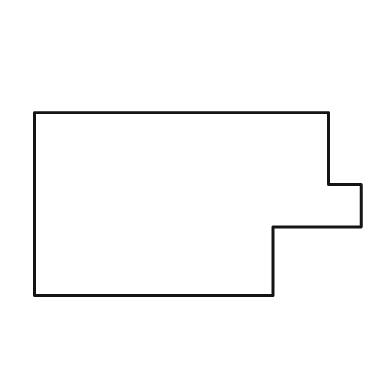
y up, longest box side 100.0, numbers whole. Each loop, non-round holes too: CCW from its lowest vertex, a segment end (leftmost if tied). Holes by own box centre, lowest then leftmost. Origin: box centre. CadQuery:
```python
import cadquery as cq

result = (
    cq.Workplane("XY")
    .moveTo(-50.0, -28.0)
    .lineTo(23.0, -28.0)
    .lineTo(23.0, -7.0)
    .lineTo(50.0, -7.0)
    .lineTo(50.0, 6.0)
    .lineTo(40.0, 6.0)
    .lineTo(40.0, 28.0)
    .lineTo(-50.0, 28.0)
    .close()
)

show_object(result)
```